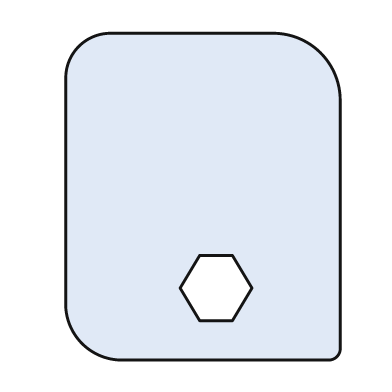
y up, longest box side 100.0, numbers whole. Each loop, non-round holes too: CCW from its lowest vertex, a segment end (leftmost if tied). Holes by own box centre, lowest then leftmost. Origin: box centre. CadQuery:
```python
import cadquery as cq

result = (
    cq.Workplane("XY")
    .moveTo(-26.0, -50.0)
    .lineTo(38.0, -50.0)
    .threePointArc((41.0, -49.0), (42.0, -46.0))
    .lineTo(42.0, 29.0)
    .threePointArc((36.0, 44.0), (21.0, 50.0))
    .lineTo(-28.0, 50.0)
    .threePointArc((-38.0, 46.0), (-42.0, 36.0))
    .lineTo(-42.0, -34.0)
    .threePointArc((-37.0, -45.0), (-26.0, -50.0))
    .close()
    .moveTo(-1.0, -38.0)
    .lineTo(9.0, -38.0)
    .lineTo(15.0, -28.0)
    .lineTo(9.0, -18.0)
    .lineTo(-1.0, -18.0)
    .lineTo(-7.0, -28.0)
    .close()
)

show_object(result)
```